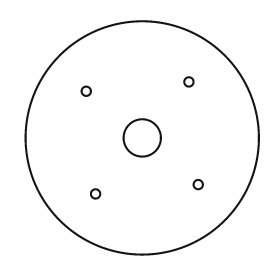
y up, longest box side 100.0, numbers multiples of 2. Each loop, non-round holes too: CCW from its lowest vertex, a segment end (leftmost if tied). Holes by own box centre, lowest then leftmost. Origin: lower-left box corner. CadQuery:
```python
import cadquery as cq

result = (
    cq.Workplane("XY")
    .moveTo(50.0, 50.0)
    .circle(50.0)
    .moveTo(30.0, 26.0)
    .circle(2.0)
    .moveTo(74.0, 30.0)
    .circle(2.0)
    .moveTo(50.0, 50.0)
    .circle(8.0)
    .moveTo(26.0, 70.0)
    .circle(2.0)
    .moveTo(70.0, 74.0)
    .circle(2.0)
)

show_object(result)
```